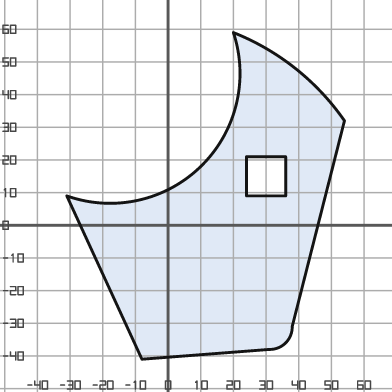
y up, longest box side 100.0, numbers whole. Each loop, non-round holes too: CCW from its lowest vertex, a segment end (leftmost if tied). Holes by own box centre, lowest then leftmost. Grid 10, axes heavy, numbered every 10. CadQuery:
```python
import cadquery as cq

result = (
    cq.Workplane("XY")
    .moveTo(-8.0, -41.0)
    .lineTo(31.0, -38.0)
    .threePointArc((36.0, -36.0), (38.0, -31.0))
    .lineTo(54.0, 32.0)
    .threePointArc((39.0, 48.0), (20.0, 59.0))
    .threePointArc((10.0, 18.0), (-31.0, 9.0))
    .close()
    .moveTo(24.0, 9.0)
    .lineTo(36.0, 9.0)
    .lineTo(36.0, 21.0)
    .lineTo(24.0, 21.0)
    .close()
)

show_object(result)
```